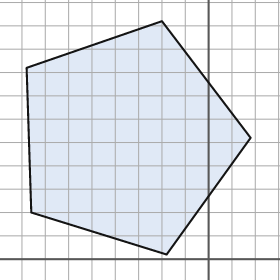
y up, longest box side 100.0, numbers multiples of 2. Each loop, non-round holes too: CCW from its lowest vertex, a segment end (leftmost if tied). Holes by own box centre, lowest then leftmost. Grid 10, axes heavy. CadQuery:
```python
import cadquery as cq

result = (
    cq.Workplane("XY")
    .moveTo(-18.0, 2.0)
    .lineTo(18.0, 52.0)
    .lineTo(-20.0, 102.0)
    .lineTo(-78.0, 82.0)
    .lineTo(-76.0, 20.0)
    .close()
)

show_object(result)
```